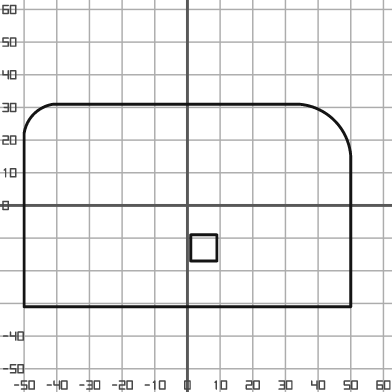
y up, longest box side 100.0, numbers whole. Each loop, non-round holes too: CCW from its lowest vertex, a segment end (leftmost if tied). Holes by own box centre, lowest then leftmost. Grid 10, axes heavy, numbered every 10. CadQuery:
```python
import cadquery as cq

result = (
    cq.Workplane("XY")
    .moveTo(-50.0, -31.0)
    .lineTo(50.0, -31.0)
    .lineTo(50.0, 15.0)
    .threePointArc((45.0, 26.0), (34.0, 31.0))
    .lineTo(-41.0, 31.0)
    .threePointArc((-47.0, 28.0), (-50.0, 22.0))
    .close()
    .moveTo(1.0, -17.0)
    .lineTo(9.0, -17.0)
    .lineTo(9.0, -9.0)
    .lineTo(1.0, -9.0)
    .close()
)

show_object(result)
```